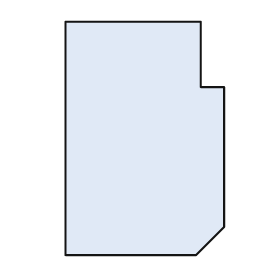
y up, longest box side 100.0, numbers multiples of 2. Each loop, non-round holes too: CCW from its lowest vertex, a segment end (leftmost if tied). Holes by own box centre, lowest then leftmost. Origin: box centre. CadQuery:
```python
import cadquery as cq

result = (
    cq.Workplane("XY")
    .moveTo(-34.0, -50.0)
    .lineTo(22.0, -50.0)
    .lineTo(34.0, -38.0)
    .lineTo(34.0, 22.0)
    .lineTo(24.0, 22.0)
    .lineTo(24.0, 50.0)
    .lineTo(-34.0, 50.0)
    .close()
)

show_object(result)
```